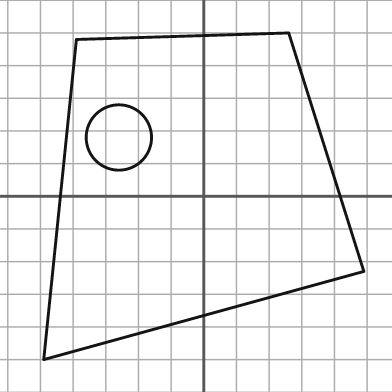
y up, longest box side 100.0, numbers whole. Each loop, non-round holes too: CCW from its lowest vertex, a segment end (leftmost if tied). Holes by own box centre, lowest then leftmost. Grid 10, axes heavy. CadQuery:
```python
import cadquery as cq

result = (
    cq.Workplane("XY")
    .moveTo(-49.0, -50.0)
    .lineTo(49.0, -23.0)
    .lineTo(26.0, 50.0)
    .lineTo(-39.0, 48.0)
    .close()
    .moveTo(-26.0, 18.0)
    .circle(10.0)
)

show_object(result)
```